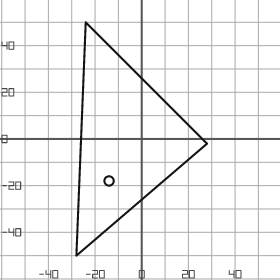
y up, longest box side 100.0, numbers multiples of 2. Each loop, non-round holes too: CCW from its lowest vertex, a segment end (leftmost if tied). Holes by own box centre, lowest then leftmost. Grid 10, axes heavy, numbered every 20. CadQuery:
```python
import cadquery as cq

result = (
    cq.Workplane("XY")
    .moveTo(-28.0, -50.0)
    .lineTo(28.0, -2.0)
    .lineTo(-24.0, 50.0)
    .close()
    .moveTo(-14.0, -18.0)
    .circle(2.0)
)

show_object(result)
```